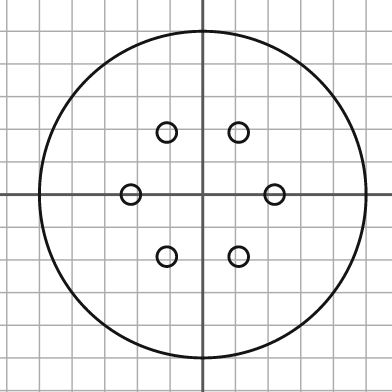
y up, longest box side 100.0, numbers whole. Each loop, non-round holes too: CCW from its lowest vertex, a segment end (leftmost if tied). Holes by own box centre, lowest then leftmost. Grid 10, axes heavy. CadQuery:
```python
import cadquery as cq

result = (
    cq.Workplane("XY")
    .moveTo(0.0, 0.0)
    .circle(50.0)
    .moveTo(-11.0, -19.0)
    .circle(3.0)
    .moveTo(11.0, -19.0)
    .circle(3.0)
    .moveTo(-22.0, 0.0)
    .circle(3.0)
    .moveTo(22.0, 0.0)
    .circle(3.0)
    .moveTo(-11.0, 19.0)
    .circle(3.0)
    .moveTo(11.0, 19.0)
    .circle(3.0)
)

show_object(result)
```